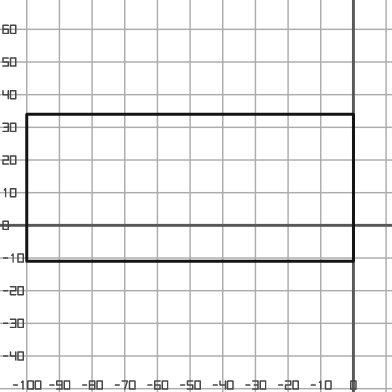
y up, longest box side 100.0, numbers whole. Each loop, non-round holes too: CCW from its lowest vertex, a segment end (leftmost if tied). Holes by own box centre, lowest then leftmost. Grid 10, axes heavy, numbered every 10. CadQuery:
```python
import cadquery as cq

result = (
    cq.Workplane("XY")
    .moveTo(-100.0, -11.0)
    .lineTo(0.0, -11.0)
    .lineTo(0.0, 34.0)
    .lineTo(-100.0, 34.0)
    .close()
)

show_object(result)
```